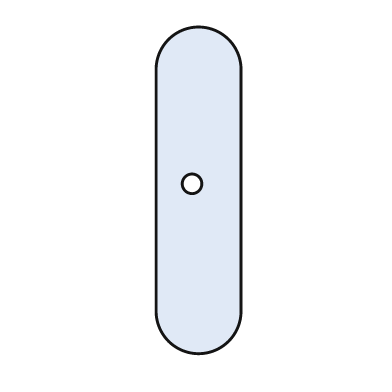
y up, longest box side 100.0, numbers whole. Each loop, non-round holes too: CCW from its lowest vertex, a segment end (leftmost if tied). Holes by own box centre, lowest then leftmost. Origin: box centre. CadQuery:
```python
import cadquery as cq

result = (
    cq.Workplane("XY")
    .moveTo(-13.0, -37.0)
    .threePointArc((0.0, -50.0), (13.0, -37.0))
    .lineTo(13.0, 37.0)
    .threePointArc((0.0, 50.0), (-13.0, 37.0))
    .close()
    .moveTo(-2.0, 2.0)
    .circle(3.0)
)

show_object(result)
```